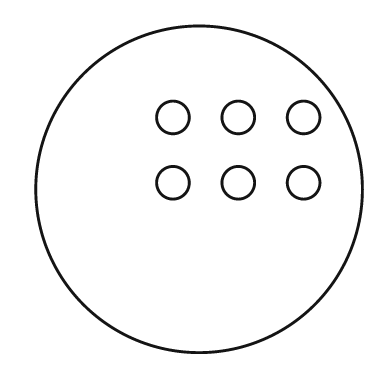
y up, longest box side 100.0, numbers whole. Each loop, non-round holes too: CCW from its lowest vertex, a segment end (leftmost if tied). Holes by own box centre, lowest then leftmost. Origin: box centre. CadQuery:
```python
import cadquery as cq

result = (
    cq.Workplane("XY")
    .moveTo(0.0, 0.0)
    .circle(50.0)
    .moveTo(-8.0, 2.0)
    .circle(5.0)
    .moveTo(12.0, 2.0)
    .circle(5.0)
    .moveTo(32.0, 2.0)
    .circle(5.0)
    .moveTo(-8.0, 22.0)
    .circle(5.0)
    .moveTo(12.0, 22.0)
    .circle(5.0)
    .moveTo(32.0, 22.0)
    .circle(5.0)
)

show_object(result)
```